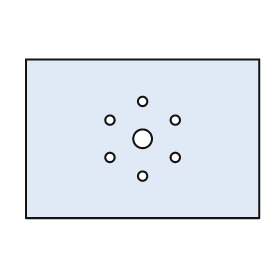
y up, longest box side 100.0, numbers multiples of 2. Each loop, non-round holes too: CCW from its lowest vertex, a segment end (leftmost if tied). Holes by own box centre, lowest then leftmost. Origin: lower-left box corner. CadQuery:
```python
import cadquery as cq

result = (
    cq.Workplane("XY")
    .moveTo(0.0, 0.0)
    .lineTo(100.0, 0.0)
    .lineTo(100.0, 68.0)
    .lineTo(0.0, 68.0)
    .close()
    .moveTo(50.0, 18.0)
    .circle(2.0)
    .moveTo(36.0, 26.0)
    .circle(2.0)
    .moveTo(64.0, 26.0)
    .circle(2.0)
    .moveTo(50.0, 34.0)
    .circle(4.0)
    .moveTo(36.0, 42.0)
    .circle(2.0)
    .moveTo(64.0, 42.0)
    .circle(2.0)
    .moveTo(50.0, 50.0)
    .circle(2.0)
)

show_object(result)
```